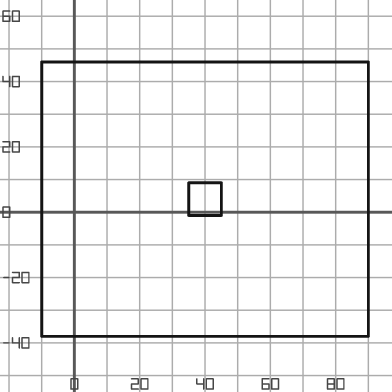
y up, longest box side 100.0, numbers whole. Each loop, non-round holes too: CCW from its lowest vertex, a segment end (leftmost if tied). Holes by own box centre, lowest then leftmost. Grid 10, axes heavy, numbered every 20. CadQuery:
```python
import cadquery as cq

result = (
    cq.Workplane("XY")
    .moveTo(-10.0, -38.0)
    .lineTo(90.0, -38.0)
    .lineTo(90.0, 46.0)
    .lineTo(-10.0, 46.0)
    .close()
    .moveTo(35.0, -1.0)
    .lineTo(45.0, -1.0)
    .lineTo(45.0, 9.0)
    .lineTo(35.0, 9.0)
    .close()
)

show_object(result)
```